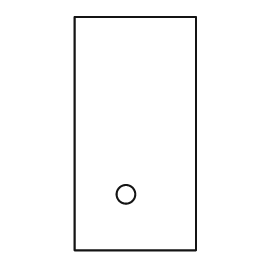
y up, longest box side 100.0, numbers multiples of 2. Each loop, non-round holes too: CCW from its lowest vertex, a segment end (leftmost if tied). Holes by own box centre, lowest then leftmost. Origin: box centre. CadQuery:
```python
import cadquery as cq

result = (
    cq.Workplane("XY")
    .moveTo(-26.0, -50.0)
    .lineTo(26.0, -50.0)
    .lineTo(26.0, 50.0)
    .lineTo(-26.0, 50.0)
    .close()
    .moveTo(-4.0, -26.0)
    .circle(4.0)
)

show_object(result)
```